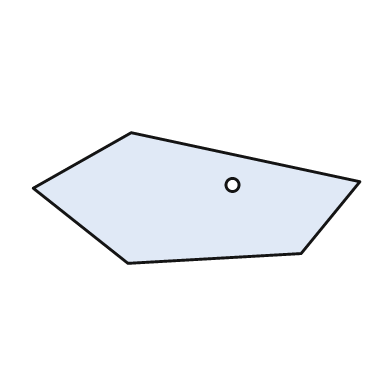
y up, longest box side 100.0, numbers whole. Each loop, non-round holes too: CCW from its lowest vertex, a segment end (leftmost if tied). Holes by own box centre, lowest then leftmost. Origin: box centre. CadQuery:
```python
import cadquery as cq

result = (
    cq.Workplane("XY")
    .moveTo(-21.0, -20.0)
    .lineTo(32.0, -17.0)
    .lineTo(50.0, 5.0)
    .lineTo(-20.0, 20.0)
    .lineTo(-50.0, 3.0)
    .close()
    .moveTo(11.0, 4.0)
    .circle(2.0)
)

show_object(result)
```